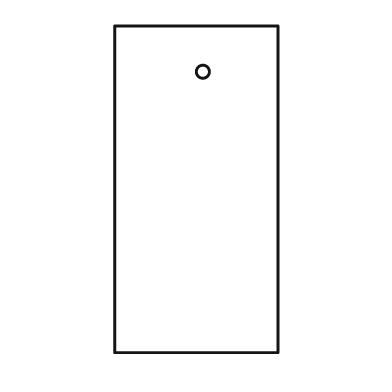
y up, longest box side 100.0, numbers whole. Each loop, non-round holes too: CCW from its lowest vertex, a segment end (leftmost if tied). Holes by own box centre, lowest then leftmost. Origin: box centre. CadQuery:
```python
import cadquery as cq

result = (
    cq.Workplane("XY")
    .moveTo(-25.0, -50.0)
    .lineTo(25.0, -50.0)
    .lineTo(25.0, 50.0)
    .lineTo(-25.0, 50.0)
    .close()
    .moveTo(2.0, 36.0)
    .circle(2.0)
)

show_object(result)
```